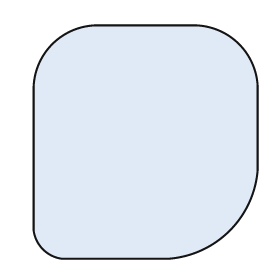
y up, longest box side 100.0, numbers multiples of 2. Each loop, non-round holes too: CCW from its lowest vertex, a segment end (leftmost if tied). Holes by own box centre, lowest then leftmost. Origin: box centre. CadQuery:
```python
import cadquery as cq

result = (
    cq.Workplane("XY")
    .moveTo(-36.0, -50.0)
    .lineTo(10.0, -50.0)
    .threePointArc((36.0, -38.0), (48.0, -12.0))
    .lineTo(48.0, 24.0)
    .threePointArc((40.0, 42.0), (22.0, 50.0))
    .lineTo(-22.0, 50.0)
    .threePointArc((-40.0, 42.0), (-48.0, 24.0))
    .lineTo(-48.0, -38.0)
    .threePointArc((-44.0, -46.0), (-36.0, -50.0))
    .close()
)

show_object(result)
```